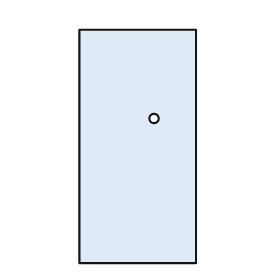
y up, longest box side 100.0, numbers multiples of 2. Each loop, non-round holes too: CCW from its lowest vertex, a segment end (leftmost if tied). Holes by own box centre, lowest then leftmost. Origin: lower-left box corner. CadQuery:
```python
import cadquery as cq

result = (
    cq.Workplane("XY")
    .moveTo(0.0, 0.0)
    .lineTo(50.0, 0.0)
    .lineTo(50.0, 100.0)
    .lineTo(0.0, 100.0)
    .close()
    .moveTo(32.0, 62.0)
    .circle(2.0)
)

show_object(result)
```